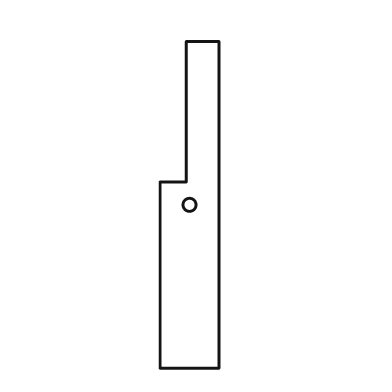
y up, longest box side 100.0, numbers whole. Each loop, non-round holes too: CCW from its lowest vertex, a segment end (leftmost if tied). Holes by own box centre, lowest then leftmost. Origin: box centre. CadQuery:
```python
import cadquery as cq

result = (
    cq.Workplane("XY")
    .moveTo(-9.0, -50.0)
    .lineTo(9.0, -50.0)
    .lineTo(9.0, 50.0)
    .lineTo(-1.0, 50.0)
    .lineTo(-1.0, 7.0)
    .lineTo(-9.0, 7.0)
    .close()
    .moveTo(0.0, 0.0)
    .circle(2.0)
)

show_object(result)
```